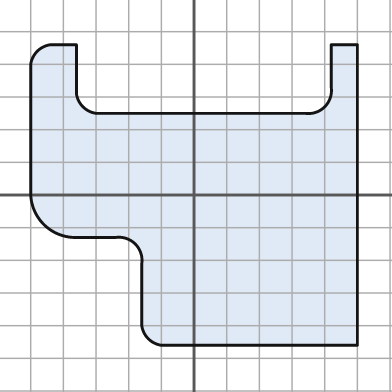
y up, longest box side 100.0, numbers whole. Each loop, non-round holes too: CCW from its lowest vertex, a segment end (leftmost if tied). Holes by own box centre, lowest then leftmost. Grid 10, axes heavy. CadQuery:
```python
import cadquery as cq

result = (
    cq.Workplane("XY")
    .moveTo(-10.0, -46.0)
    .lineTo(50.0, -46.0)
    .lineTo(50.0, 46.0)
    .lineTo(42.0, 46.0)
    .lineTo(42.0, 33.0)
    .threePointArc((40.0, 27.0), (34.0, 25.0))
    .lineTo(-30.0, 25.0)
    .threePointArc((-34.0, 27.0), (-36.0, 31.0))
    .lineTo(-36.0, 46.0)
    .lineTo(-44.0, 46.0)
    .threePointArc((-48.0, 44.0), (-50.0, 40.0))
    .lineTo(-50.0, 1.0)
    .threePointArc((-46.0, -9.0), (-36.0, -13.0))
    .lineTo(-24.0, -13.0)
    .threePointArc((-18.0, -15.0), (-16.0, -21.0))
    .lineTo(-16.0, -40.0)
    .threePointArc((-14.0, -44.0), (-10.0, -46.0))
    .close()
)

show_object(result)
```